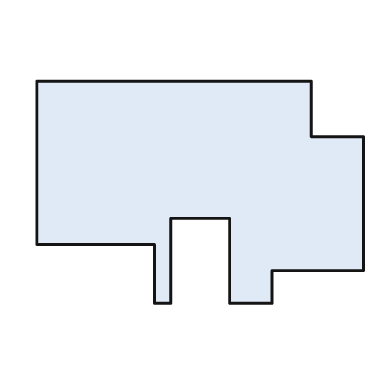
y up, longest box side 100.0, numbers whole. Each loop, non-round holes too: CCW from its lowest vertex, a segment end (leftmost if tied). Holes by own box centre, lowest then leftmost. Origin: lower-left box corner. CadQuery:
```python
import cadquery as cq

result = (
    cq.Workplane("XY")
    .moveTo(36.0, 0.0)
    .lineTo(41.0, 0.0)
    .lineTo(41.0, 26.0)
    .lineTo(59.0, 26.0)
    .lineTo(59.0, 0.0)
    .lineTo(72.0, 0.0)
    .lineTo(72.0, 10.0)
    .lineTo(100.0, 10.0)
    .lineTo(100.0, 51.0)
    .lineTo(84.0, 51.0)
    .lineTo(84.0, 68.0)
    .lineTo(0.0, 68.0)
    .lineTo(0.0, 18.0)
    .lineTo(36.0, 18.0)
    .close()
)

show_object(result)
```